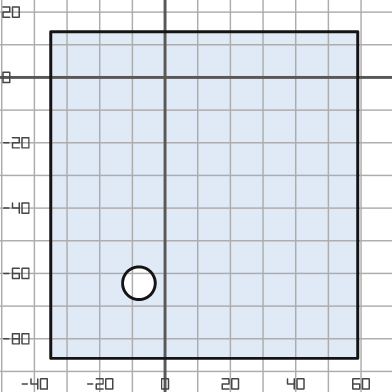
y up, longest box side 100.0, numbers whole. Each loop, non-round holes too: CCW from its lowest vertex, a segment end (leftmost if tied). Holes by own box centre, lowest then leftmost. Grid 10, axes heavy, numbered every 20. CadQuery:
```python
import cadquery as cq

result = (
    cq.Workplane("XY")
    .moveTo(-35.0, -86.0)
    .lineTo(59.0, -86.0)
    .lineTo(59.0, 14.0)
    .lineTo(-35.0, 14.0)
    .close()
    .moveTo(-8.0, -63.0)
    .circle(5.0)
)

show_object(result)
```